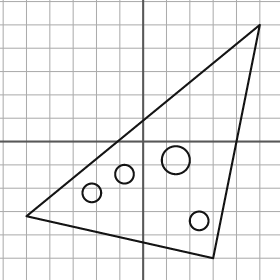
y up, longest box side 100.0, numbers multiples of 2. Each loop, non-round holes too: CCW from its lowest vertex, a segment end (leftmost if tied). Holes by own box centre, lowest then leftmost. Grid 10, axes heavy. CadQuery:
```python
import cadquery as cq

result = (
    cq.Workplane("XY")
    .moveTo(30.0, -50.0)
    .lineTo(50.0, 50.0)
    .lineTo(-50.0, -32.0)
    .close()
    .moveTo(24.0, -34.0)
    .circle(4.0)
    .moveTo(-22.0, -22.0)
    .circle(4.0)
    .moveTo(-8.0, -14.0)
    .circle(4.0)
    .moveTo(14.0, -8.0)
    .circle(6.0)
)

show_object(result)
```